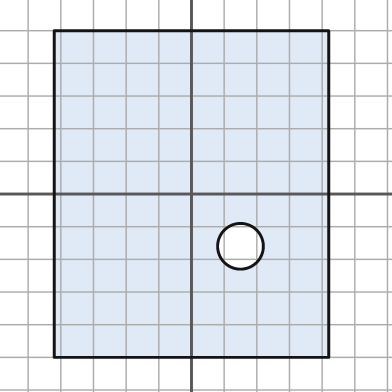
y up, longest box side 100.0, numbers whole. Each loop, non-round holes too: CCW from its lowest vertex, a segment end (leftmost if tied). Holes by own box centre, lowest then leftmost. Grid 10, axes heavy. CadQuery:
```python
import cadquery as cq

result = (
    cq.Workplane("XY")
    .moveTo(-42.0, -50.0)
    .lineTo(42.0, -50.0)
    .lineTo(42.0, 50.0)
    .lineTo(-42.0, 50.0)
    .close()
    .moveTo(15.0, -16.0)
    .circle(7.0)
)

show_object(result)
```